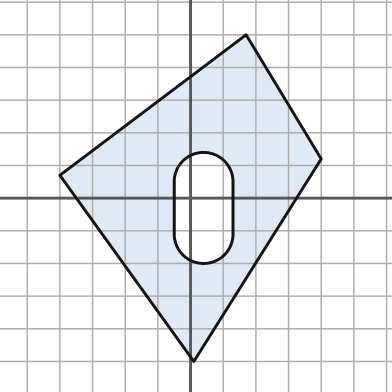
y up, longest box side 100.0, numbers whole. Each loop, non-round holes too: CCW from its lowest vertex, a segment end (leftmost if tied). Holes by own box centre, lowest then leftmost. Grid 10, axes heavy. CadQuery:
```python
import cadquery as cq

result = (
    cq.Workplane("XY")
    .moveTo(1.0, -50.0)
    .lineTo(40.0, 12.0)
    .lineTo(17.0, 50.0)
    .lineTo(-40.0, 7.0)
    .close()
    .moveTo(-5.0, -11.0)
    .threePointArc((4.0, -20.0), (13.0, -11.0))
    .lineTo(13.0, 5.0)
    .threePointArc((4.0, 14.0), (-5.0, 5.0))
    .close()
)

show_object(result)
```